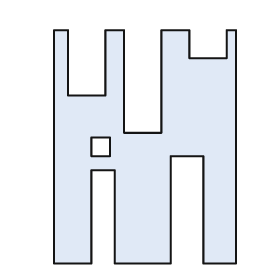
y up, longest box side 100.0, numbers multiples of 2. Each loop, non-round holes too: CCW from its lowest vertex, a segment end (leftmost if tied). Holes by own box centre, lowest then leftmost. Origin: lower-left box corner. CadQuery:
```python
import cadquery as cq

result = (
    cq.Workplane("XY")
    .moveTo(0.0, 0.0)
    .lineTo(16.0, 0.0)
    .lineTo(16.0, 40.0)
    .lineTo(26.0, 40.0)
    .lineTo(26.0, 0.0)
    .lineTo(50.0, 0.0)
    .lineTo(50.0, 46.0)
    .lineTo(64.0, 46.0)
    .lineTo(64.0, 0.0)
    .lineTo(78.0, 0.0)
    .lineTo(78.0, 100.0)
    .lineTo(74.0, 100.0)
    .lineTo(74.0, 88.0)
    .lineTo(58.0, 88.0)
    .lineTo(58.0, 100.0)
    .lineTo(46.0, 100.0)
    .lineTo(46.0, 56.0)
    .lineTo(30.0, 56.0)
    .lineTo(30.0, 100.0)
    .lineTo(22.0, 100.0)
    .lineTo(22.0, 72.0)
    .lineTo(6.0, 72.0)
    .lineTo(6.0, 100.0)
    .lineTo(0.0, 100.0)
    .close()
    .moveTo(16.0, 46.0)
    .lineTo(24.0, 46.0)
    .lineTo(24.0, 54.0)
    .lineTo(16.0, 54.0)
    .close()
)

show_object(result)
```